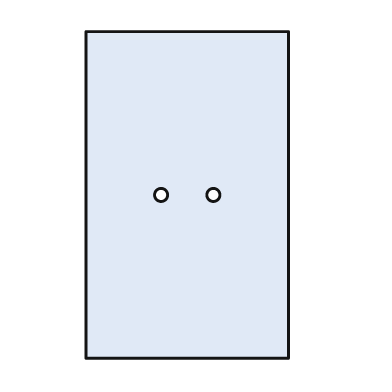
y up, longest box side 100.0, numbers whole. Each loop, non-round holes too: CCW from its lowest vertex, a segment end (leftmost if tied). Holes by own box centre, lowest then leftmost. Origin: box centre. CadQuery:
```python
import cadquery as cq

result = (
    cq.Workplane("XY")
    .moveTo(-31.0, -50.0)
    .lineTo(31.0, -50.0)
    .lineTo(31.0, 50.0)
    .lineTo(-31.0, 50.0)
    .close()
    .moveTo(-8.0, 0.0)
    .circle(2.0)
    .moveTo(8.0, 0.0)
    .circle(2.0)
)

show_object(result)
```